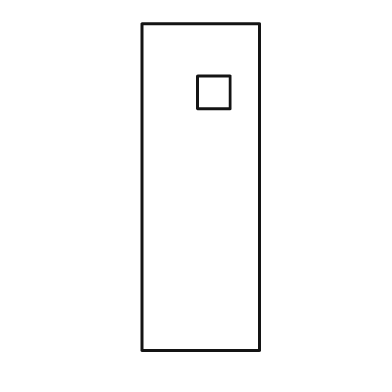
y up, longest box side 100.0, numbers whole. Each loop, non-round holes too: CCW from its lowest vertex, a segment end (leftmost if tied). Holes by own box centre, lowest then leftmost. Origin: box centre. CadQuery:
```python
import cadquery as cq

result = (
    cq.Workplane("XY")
    .moveTo(-18.0, -50.0)
    .lineTo(18.0, -50.0)
    .lineTo(18.0, 50.0)
    .lineTo(-18.0, 50.0)
    .close()
    .moveTo(-1.0, 24.0)
    .lineTo(9.0, 24.0)
    .lineTo(9.0, 34.0)
    .lineTo(-1.0, 34.0)
    .close()
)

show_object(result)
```